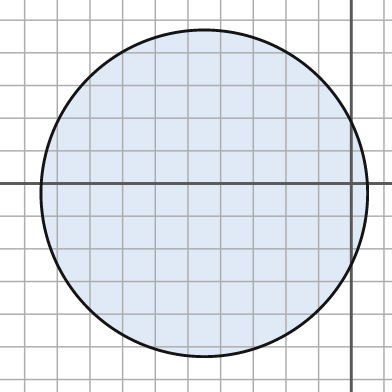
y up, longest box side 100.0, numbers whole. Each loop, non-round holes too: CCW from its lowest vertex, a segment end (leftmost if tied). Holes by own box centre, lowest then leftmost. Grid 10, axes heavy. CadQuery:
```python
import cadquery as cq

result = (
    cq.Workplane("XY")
    .moveTo(-45.0, -3.0)
    .circle(50.0)
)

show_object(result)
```